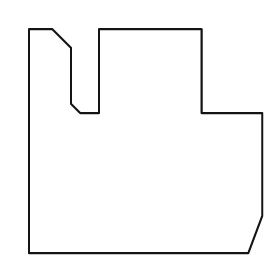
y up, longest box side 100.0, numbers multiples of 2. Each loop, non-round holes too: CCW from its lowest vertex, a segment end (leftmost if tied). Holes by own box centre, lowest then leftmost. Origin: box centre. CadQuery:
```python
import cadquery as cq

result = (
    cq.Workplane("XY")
    .moveTo(-50.0, -48.0)
    .lineTo(44.0, -48.0)
    .lineTo(50.0, -32.0)
    .lineTo(50.0, 12.0)
    .lineTo(24.0, 12.0)
    .lineTo(24.0, 48.0)
    .lineTo(-20.0, 48.0)
    .lineTo(-20.0, 12.0)
    .lineTo(-28.0, 12.0)
    .lineTo(-32.0, 16.0)
    .lineTo(-32.0, 40.0)
    .lineTo(-40.0, 48.0)
    .lineTo(-50.0, 48.0)
    .close()
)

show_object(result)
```